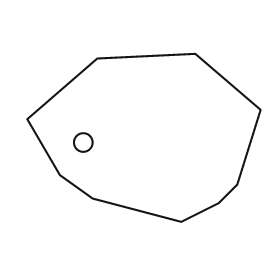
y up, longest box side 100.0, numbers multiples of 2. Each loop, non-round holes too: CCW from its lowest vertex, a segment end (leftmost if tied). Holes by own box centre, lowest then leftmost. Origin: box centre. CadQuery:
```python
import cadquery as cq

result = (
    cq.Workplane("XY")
    .moveTo(16.0, -36.0)
    .lineTo(32.0, -28.0)
    .lineTo(40.0, -20.0)
    .lineTo(50.0, 12.0)
    .lineTo(22.0, 36.0)
    .lineTo(-20.0, 34.0)
    .lineTo(-50.0, 8.0)
    .lineTo(-36.0, -16.0)
    .lineTo(-22.0, -26.0)
    .close()
    .moveTo(-26.0, -2.0)
    .circle(4.0)
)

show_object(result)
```